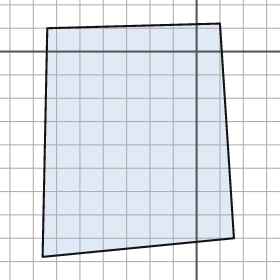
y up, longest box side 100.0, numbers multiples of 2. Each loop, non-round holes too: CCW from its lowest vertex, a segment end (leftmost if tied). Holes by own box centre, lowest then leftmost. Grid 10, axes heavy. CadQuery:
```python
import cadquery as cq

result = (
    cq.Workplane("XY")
    .moveTo(-66.0, -88.0)
    .lineTo(16.0, -80.0)
    .lineTo(10.0, 12.0)
    .lineTo(-64.0, 10.0)
    .close()
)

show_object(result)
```